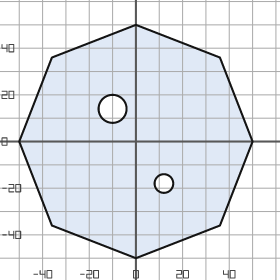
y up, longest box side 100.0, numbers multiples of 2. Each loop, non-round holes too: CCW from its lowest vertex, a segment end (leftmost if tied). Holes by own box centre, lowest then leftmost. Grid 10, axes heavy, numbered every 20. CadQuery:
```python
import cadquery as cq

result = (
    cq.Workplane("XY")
    .moveTo(0.0, -50.0)
    .lineTo(36.0, -36.0)
    .lineTo(50.0, 0.0)
    .lineTo(36.0, 36.0)
    .lineTo(0.0, 50.0)
    .lineTo(-36.0, 36.0)
    .lineTo(-50.0, 0.0)
    .lineTo(-36.0, -36.0)
    .close()
    .moveTo(12.0, -18.0)
    .circle(4.0)
    .moveTo(-10.0, 14.0)
    .circle(6.0)
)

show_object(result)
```